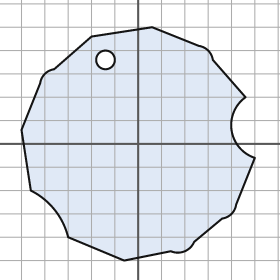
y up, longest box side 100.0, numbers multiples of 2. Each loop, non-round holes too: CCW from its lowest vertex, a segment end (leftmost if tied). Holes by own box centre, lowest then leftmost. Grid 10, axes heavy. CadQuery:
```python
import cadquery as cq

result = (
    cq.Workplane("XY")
    .moveTo(-6.0, -50.0)
    .lineTo(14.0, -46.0)
    .threePointArc((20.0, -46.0), (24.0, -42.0))
    .lineTo(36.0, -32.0)
    .threePointArc((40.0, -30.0), (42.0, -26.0))
    .lineTo(50.0, -6.0)
    .threePointArc((40.0, 6.0), (46.0, 20.0))
    .lineTo(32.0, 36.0)
    .threePointArc((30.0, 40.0), (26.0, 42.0))
    .lineTo(6.0, 50.0)
    .lineTo(-20.0, 46.0)
    .lineTo(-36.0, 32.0)
    .threePointArc((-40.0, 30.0), (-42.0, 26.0))
    .lineTo(-50.0, 6.0)
    .lineTo(-46.0, -20.0)
    .threePointArc((-36.0, -28.0), (-30.0, -40.0))
    .close()
    .moveTo(-14.0, 36.0)
    .circle(4.0)
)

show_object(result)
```